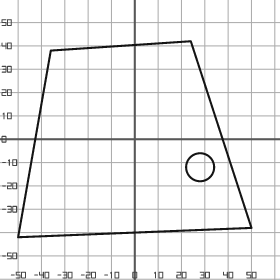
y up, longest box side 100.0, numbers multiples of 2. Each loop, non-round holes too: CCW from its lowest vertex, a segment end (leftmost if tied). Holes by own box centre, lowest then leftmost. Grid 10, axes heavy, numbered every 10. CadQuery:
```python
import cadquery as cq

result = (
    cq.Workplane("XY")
    .moveTo(-50.0, -42.0)
    .lineTo(50.0, -38.0)
    .lineTo(24.0, 42.0)
    .lineTo(-36.0, 38.0)
    .close()
    .moveTo(28.0, -12.0)
    .circle(6.0)
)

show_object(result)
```